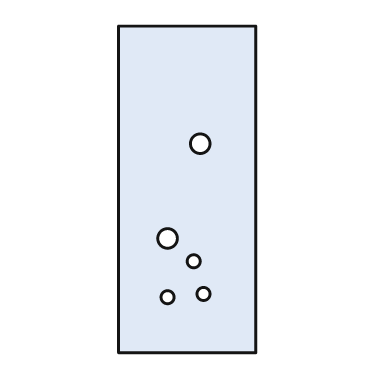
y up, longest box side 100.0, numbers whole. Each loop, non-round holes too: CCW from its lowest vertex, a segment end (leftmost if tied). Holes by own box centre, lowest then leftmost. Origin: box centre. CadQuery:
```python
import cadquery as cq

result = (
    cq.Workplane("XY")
    .moveTo(-21.0, -50.0)
    .lineTo(21.0, -50.0)
    .lineTo(21.0, 50.0)
    .lineTo(-21.0, 50.0)
    .close()
    .moveTo(-6.0, -33.0)
    .circle(2.0)
    .moveTo(5.0, -32.0)
    .circle(2.0)
    .moveTo(2.0, -22.0)
    .circle(2.0)
    .moveTo(-6.0, -15.0)
    .circle(3.0)
    .moveTo(4.0, 14.0)
    .circle(3.0)
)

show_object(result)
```